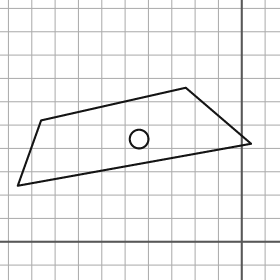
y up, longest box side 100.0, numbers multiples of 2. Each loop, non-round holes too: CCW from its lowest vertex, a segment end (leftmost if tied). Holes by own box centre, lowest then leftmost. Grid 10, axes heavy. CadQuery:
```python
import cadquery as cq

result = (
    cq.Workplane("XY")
    .moveTo(-96.0, 24.0)
    .lineTo(4.0, 42.0)
    .lineTo(-24.0, 66.0)
    .lineTo(-86.0, 52.0)
    .close()
    .moveTo(-44.0, 44.0)
    .circle(4.0)
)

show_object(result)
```